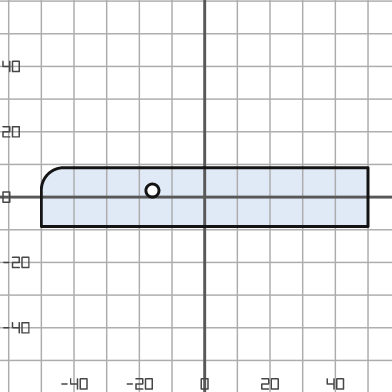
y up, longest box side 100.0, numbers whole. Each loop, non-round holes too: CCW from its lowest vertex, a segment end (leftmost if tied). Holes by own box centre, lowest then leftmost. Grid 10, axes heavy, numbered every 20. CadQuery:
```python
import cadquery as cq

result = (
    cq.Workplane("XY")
    .moveTo(-50.0, -9.0)
    .lineTo(50.0, -9.0)
    .lineTo(50.0, 9.0)
    .lineTo(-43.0, 9.0)
    .threePointArc((-48.0, 7.0), (-50.0, 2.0))
    .close()
    .moveTo(-16.0, 2.0)
    .circle(2.0)
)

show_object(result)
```